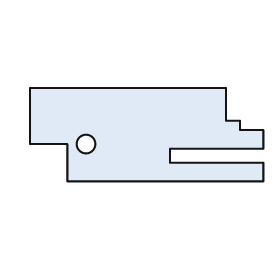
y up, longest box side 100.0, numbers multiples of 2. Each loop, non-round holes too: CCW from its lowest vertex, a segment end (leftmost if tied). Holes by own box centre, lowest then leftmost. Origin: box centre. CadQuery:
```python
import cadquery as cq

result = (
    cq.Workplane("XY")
    .moveTo(-34.0, -20.0)
    .lineTo(50.0, -20.0)
    .lineTo(50.0, -12.0)
    .lineTo(10.0, -12.0)
    .lineTo(10.0, -6.0)
    .lineTo(50.0, -6.0)
    .lineTo(50.0, 2.0)
    .lineTo(40.0, 2.0)
    .lineTo(40.0, 6.0)
    .lineTo(34.0, 6.0)
    .lineTo(34.0, 20.0)
    .lineTo(-50.0, 20.0)
    .lineTo(-50.0, -4.0)
    .lineTo(-34.0, -4.0)
    .close()
    .moveTo(-26.0, -4.0)
    .circle(4.0)
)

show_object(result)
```